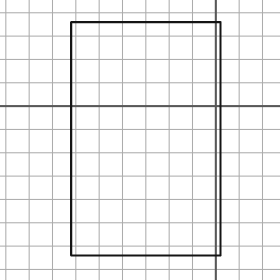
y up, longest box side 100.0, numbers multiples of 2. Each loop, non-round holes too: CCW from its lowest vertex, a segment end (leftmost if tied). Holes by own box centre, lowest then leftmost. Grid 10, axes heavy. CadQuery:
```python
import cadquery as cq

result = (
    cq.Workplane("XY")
    .moveTo(-62.0, -64.0)
    .lineTo(2.0, -64.0)
    .lineTo(2.0, 36.0)
    .lineTo(-62.0, 36.0)
    .close()
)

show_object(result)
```